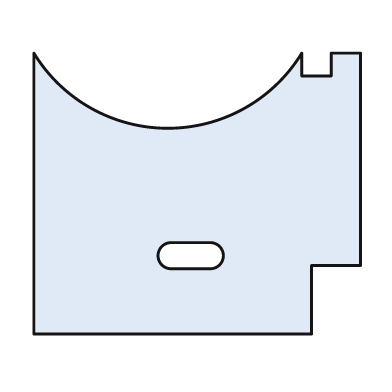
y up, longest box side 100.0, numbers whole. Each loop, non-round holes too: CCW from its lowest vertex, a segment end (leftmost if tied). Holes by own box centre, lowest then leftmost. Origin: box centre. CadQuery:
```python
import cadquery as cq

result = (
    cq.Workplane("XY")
    .moveTo(-50.0, -43.0)
    .lineTo(35.0, -43.0)
    .lineTo(35.0, -22.0)
    .lineTo(50.0, -22.0)
    .lineTo(50.0, 43.0)
    .lineTo(41.0, 43.0)
    .lineTo(41.0, 36.0)
    .lineTo(32.0, 36.0)
    .lineTo(32.0, 43.0)
    .threePointArc((-9.0, 20.0), (-50.0, 43.0))
    .close()
    .moveTo(-8.0, -23.0)
    .lineTo(4.0, -23.0)
    .threePointArc((8.0, -19.0), (4.0, -15.0))
    .lineTo(-8.0, -15.0)
    .threePointArc((-12.0, -19.0), (-8.0, -23.0))
    .close()
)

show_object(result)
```